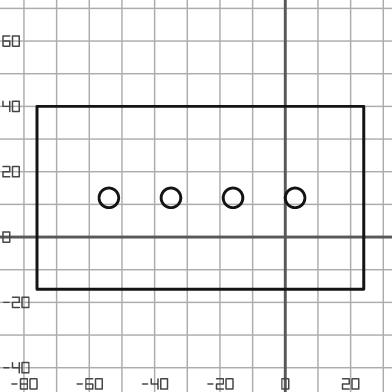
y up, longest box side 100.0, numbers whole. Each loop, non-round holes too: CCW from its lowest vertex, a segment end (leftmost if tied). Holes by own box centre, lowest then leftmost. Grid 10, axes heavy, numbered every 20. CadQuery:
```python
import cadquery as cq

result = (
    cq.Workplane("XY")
    .moveTo(-76.0, -16.0)
    .lineTo(24.0, -16.0)
    .lineTo(24.0, 40.0)
    .lineTo(-76.0, 40.0)
    .close()
    .moveTo(-54.0, 12.0)
    .circle(3.0)
    .moveTo(-35.0, 12.0)
    .circle(3.0)
    .moveTo(-16.0, 12.0)
    .circle(3.0)
    .moveTo(3.0, 12.0)
    .circle(3.0)
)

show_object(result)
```